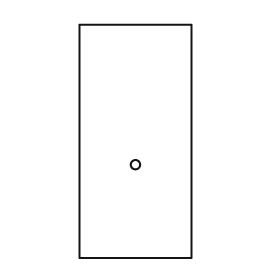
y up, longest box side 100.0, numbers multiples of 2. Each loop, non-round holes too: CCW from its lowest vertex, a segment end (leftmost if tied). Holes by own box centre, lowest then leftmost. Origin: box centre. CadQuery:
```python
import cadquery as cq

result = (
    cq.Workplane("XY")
    .moveTo(-24.0, -50.0)
    .lineTo(24.0, -50.0)
    .lineTo(24.0, 50.0)
    .lineTo(-24.0, 50.0)
    .close()
    .moveTo(0.0, -10.0)
    .circle(2.0)
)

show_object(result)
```